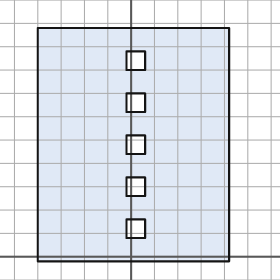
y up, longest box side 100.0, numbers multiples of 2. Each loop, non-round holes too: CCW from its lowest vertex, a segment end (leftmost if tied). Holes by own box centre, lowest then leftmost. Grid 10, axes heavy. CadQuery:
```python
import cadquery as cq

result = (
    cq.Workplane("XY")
    .moveTo(-40.0, -2.0)
    .lineTo(42.0, -2.0)
    .lineTo(42.0, 98.0)
    .lineTo(-40.0, 98.0)
    .close()
    .moveTo(-2.0, 8.0)
    .lineTo(6.0, 8.0)
    .lineTo(6.0, 16.0)
    .lineTo(-2.0, 16.0)
    .close()
    .moveTo(-2.0, 26.0)
    .lineTo(6.0, 26.0)
    .lineTo(6.0, 34.0)
    .lineTo(-2.0, 34.0)
    .close()
    .moveTo(-2.0, 44.0)
    .lineTo(6.0, 44.0)
    .lineTo(6.0, 52.0)
    .lineTo(-2.0, 52.0)
    .close()
    .moveTo(-2.0, 62.0)
    .lineTo(6.0, 62.0)
    .lineTo(6.0, 70.0)
    .lineTo(-2.0, 70.0)
    .close()
    .moveTo(-2.0, 80.0)
    .lineTo(6.0, 80.0)
    .lineTo(6.0, 88.0)
    .lineTo(-2.0, 88.0)
    .close()
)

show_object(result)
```